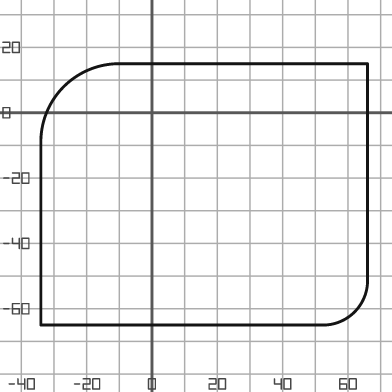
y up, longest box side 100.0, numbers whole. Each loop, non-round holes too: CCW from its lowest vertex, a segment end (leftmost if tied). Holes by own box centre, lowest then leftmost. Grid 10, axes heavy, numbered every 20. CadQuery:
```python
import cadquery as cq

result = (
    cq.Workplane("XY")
    .moveTo(-34.0, -65.0)
    .lineTo(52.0, -65.0)
    .threePointArc((62.0, -61.0), (66.0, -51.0))
    .lineTo(66.0, 15.0)
    .lineTo(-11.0, 15.0)
    .threePointArc((-27.0, 8.0), (-34.0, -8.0))
    .close()
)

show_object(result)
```